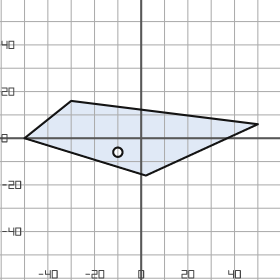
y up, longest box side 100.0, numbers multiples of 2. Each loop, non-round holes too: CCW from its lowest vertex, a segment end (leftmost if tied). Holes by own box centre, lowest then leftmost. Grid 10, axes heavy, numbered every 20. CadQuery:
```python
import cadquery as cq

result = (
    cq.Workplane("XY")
    .moveTo(2.0, -16.0)
    .lineTo(50.0, 6.0)
    .lineTo(-30.0, 16.0)
    .lineTo(-50.0, 0.0)
    .close()
    .moveTo(-10.0, -6.0)
    .circle(2.0)
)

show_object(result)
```